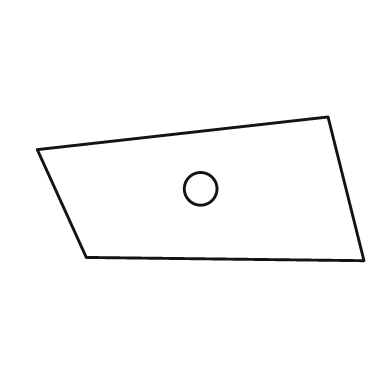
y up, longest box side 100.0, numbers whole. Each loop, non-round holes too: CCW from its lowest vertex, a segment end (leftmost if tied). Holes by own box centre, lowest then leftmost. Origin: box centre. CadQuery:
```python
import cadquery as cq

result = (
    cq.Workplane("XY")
    .moveTo(50.0, -22.0)
    .lineTo(39.0, 22.0)
    .lineTo(-50.0, 12.0)
    .lineTo(-35.0, -21.0)
    .close()
    .moveTo(0.0, 0.0)
    .circle(5.0)
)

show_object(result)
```